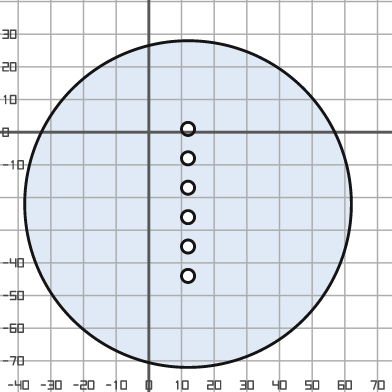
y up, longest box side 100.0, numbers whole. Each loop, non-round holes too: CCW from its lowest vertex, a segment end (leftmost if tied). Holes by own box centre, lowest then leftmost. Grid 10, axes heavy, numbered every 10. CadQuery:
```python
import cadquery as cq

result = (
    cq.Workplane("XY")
    .moveTo(12.0, -22.0)
    .circle(50.0)
    .moveTo(12.0, -44.0)
    .circle(2.0)
    .moveTo(12.0, -35.0)
    .circle(2.0)
    .moveTo(12.0, -26.0)
    .circle(2.0)
    .moveTo(12.0, -17.0)
    .circle(2.0)
    .moveTo(12.0, -8.0)
    .circle(2.0)
    .moveTo(12.0, 1.0)
    .circle(2.0)
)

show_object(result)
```